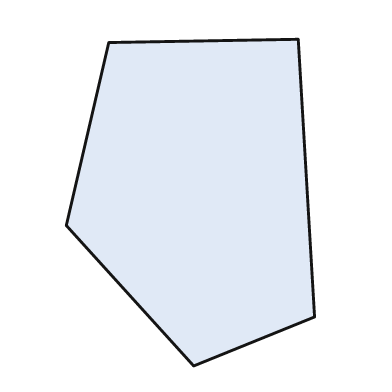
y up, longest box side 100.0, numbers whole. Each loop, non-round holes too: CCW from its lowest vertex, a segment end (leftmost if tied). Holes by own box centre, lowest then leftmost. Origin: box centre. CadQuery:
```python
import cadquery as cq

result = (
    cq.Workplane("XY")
    .moveTo(1.0, -50.0)
    .lineTo(38.0, -35.0)
    .lineTo(33.0, 50.0)
    .lineTo(-25.0, 49.0)
    .lineTo(-38.0, -7.0)
    .close()
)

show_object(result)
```